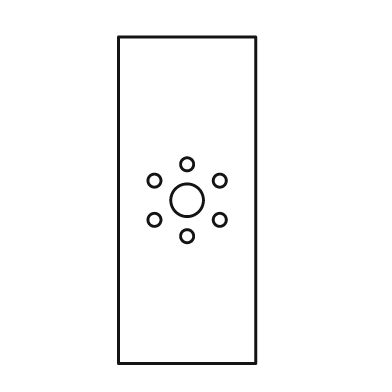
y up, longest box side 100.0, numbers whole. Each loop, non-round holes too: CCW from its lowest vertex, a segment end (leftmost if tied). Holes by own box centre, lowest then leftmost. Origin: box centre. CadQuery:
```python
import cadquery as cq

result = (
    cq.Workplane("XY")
    .moveTo(-21.0, -50.0)
    .lineTo(21.0, -50.0)
    .lineTo(21.0, 50.0)
    .lineTo(-21.0, 50.0)
    .close()
    .moveTo(0.0, -11.0)
    .circle(2.0)
    .moveTo(-10.0, -6.0)
    .circle(2.0)
    .moveTo(10.0, -6.0)
    .circle(2.0)
    .moveTo(0.0, 0.0)
    .circle(5.0)
    .moveTo(-10.0, 6.0)
    .circle(2.0)
    .moveTo(10.0, 6.0)
    .circle(2.0)
    .moveTo(0.0, 11.0)
    .circle(2.0)
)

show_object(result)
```